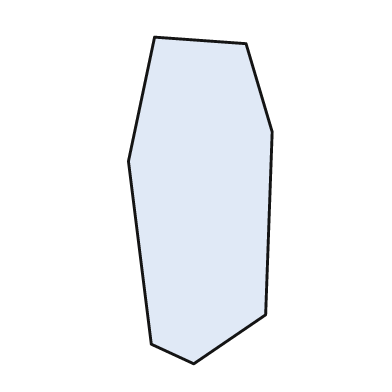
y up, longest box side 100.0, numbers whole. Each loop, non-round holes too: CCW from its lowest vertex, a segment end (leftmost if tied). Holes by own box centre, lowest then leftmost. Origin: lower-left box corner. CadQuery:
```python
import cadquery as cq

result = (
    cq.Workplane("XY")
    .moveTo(20.0, 0.0)
    .lineTo(42.0, 15.0)
    .lineTo(44.0, 71.0)
    .lineTo(36.0, 98.0)
    .lineTo(8.0, 100.0)
    .lineTo(0.0, 62.0)
    .lineTo(7.0, 6.0)
    .close()
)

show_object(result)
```